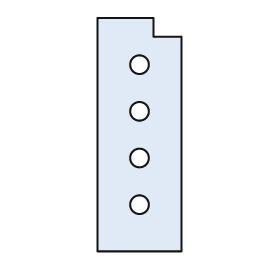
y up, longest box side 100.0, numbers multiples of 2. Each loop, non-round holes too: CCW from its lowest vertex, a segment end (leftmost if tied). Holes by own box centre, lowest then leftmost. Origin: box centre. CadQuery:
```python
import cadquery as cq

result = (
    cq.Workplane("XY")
    .moveTo(-18.0, -50.0)
    .lineTo(18.0, -50.0)
    .lineTo(18.0, 42.0)
    .lineTo(6.0, 42.0)
    .lineTo(6.0, 50.0)
    .lineTo(-18.0, 50.0)
    .close()
    .moveTo(0.0, -30.0)
    .circle(4.0)
    .moveTo(0.0, -10.0)
    .circle(4.0)
    .moveTo(0.0, 10.0)
    .circle(4.0)
    .moveTo(0.0, 30.0)
    .circle(4.0)
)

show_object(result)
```